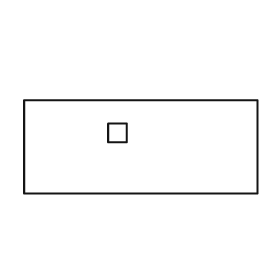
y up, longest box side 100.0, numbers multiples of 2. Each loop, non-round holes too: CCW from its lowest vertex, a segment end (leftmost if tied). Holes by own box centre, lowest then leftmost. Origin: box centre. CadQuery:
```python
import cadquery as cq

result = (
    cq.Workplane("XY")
    .moveTo(-50.0, -20.0)
    .lineTo(50.0, -20.0)
    .lineTo(50.0, 20.0)
    .lineTo(-50.0, 20.0)
    .close()
    .moveTo(-14.0, 2.0)
    .lineTo(-6.0, 2.0)
    .lineTo(-6.0, 10.0)
    .lineTo(-14.0, 10.0)
    .close()
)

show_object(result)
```